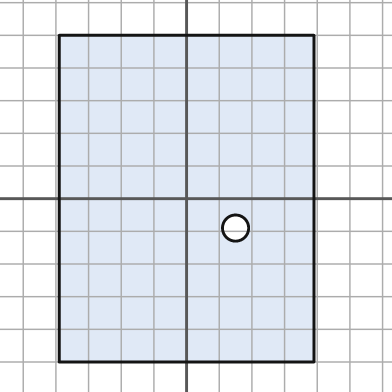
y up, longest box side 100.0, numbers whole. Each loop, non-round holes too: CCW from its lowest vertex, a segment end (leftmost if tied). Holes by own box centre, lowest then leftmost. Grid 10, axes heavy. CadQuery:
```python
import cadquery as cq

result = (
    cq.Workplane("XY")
    .moveTo(-39.0, -50.0)
    .lineTo(39.0, -50.0)
    .lineTo(39.0, 50.0)
    .lineTo(-39.0, 50.0)
    .close()
    .moveTo(15.0, -9.0)
    .circle(4.0)
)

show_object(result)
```